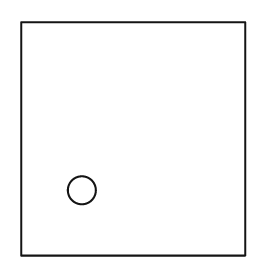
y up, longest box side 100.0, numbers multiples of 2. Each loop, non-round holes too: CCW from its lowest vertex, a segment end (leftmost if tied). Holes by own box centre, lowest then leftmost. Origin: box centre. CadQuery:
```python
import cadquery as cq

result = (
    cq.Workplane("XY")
    .moveTo(-48.0, -50.0)
    .lineTo(48.0, -50.0)
    .lineTo(48.0, 50.0)
    .lineTo(-48.0, 50.0)
    .close()
    .moveTo(-22.0, -22.0)
    .circle(6.0)
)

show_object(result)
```